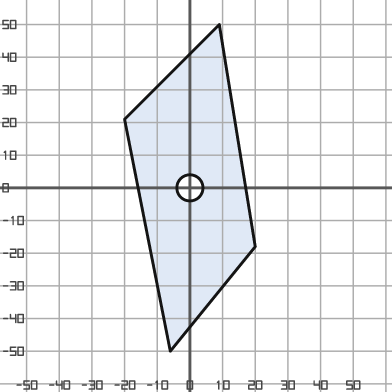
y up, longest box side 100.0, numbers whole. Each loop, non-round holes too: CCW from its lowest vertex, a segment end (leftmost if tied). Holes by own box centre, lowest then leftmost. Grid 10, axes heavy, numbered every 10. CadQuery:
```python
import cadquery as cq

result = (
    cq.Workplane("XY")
    .moveTo(-6.0, -50.0)
    .lineTo(20.0, -18.0)
    .lineTo(9.0, 50.0)
    .lineTo(-20.0, 21.0)
    .close()
    .moveTo(0.0, 0.0)
    .circle(4.0)
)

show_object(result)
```